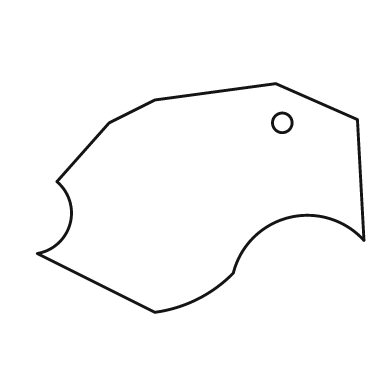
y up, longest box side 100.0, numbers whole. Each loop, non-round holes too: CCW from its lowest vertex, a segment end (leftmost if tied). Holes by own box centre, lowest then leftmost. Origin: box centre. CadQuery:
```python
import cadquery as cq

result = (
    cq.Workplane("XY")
    .moveTo(-14.0, -35.0)
    .threePointArc((-1.0, -31.0), (10.0, -23.0))
    .threePointArc((27.0, -6.0), (50.0, -13.0))
    .lineTo(48.0, 24.0)
    .lineTo(23.0, 35.0)
    .lineTo(-14.0, 30.0)
    .lineTo(-28.0, 23.0)
    .lineTo(-44.0, 5.0)
    .threePointArc((-40.0, -8.0), (-50.0, -17.0))
    .close()
    .moveTo(25.0, 23.0)
    .circle(3.0)
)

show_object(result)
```